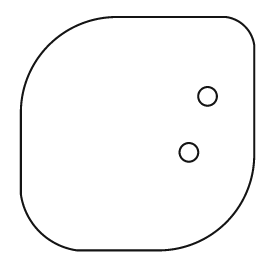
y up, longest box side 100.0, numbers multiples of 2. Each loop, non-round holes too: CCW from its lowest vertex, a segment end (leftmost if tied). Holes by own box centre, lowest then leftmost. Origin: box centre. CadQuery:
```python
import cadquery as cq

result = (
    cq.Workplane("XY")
    .moveTo(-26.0, -50.0)
    .lineTo(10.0, -50.0)
    .threePointArc((38.0, -38.0), (50.0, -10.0))
    .lineTo(50.0, 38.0)
    .threePointArc((46.0, 46.0), (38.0, 50.0))
    .lineTo(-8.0, 50.0)
    .threePointArc((-38.0, 38.0), (-50.0, 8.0))
    .lineTo(-50.0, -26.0)
    .threePointArc((-42.0, -42.0), (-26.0, -50.0))
    .close()
    .moveTo(22.0, -8.0)
    .circle(4.0)
    .moveTo(30.0, 16.0)
    .circle(4.0)
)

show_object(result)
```